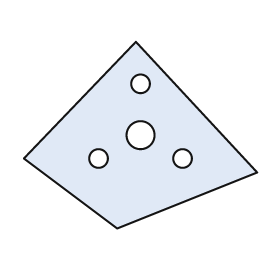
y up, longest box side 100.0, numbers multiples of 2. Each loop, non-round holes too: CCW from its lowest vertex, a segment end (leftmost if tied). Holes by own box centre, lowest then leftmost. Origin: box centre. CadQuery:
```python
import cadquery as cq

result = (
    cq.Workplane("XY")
    .moveTo(-10.0, -40.0)
    .lineTo(50.0, -16.0)
    .lineTo(-2.0, 40.0)
    .lineTo(-50.0, -10.0)
    .close()
    .moveTo(-18.0, -10.0)
    .circle(4.0)
    .moveTo(18.0, -10.0)
    .circle(4.0)
    .moveTo(0.0, 0.0)
    .circle(6.0)
    .moveTo(0.0, 22.0)
    .circle(4.0)
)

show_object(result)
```